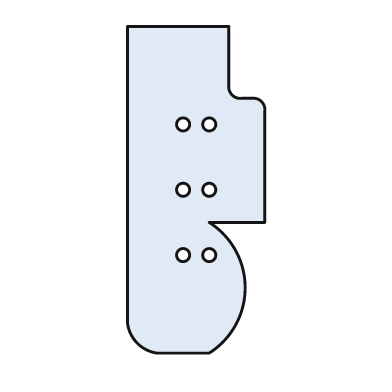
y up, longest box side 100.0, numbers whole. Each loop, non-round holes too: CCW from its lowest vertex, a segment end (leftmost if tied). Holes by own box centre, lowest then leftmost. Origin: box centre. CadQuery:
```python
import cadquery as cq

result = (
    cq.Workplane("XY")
    .moveTo(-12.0, -50.0)
    .lineTo(4.0, -50.0)
    .threePointArc((15.0, -30.0), (4.0, -10.0))
    .lineTo(21.0, -10.0)
    .lineTo(21.0, 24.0)
    .threePointArc((20.0, 27.0), (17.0, 28.0))
    .lineTo(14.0, 28.0)
    .threePointArc((11.0, 29.0), (10.0, 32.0))
    .lineTo(10.0, 50.0)
    .lineTo(-21.0, 50.0)
    .lineTo(-21.0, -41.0)
    .threePointArc((-18.0, -47.0), (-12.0, -50.0))
    .close()
    .moveTo(-4.0, -20.0)
    .circle(2.0)
    .moveTo(4.0, -20.0)
    .circle(2.0)
    .moveTo(-4.0, 0.0)
    .circle(2.0)
    .moveTo(4.0, 0.0)
    .circle(2.0)
    .moveTo(-4.0, 20.0)
    .circle(2.0)
    .moveTo(4.0, 20.0)
    .circle(2.0)
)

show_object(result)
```